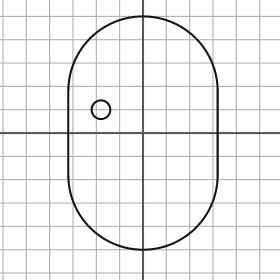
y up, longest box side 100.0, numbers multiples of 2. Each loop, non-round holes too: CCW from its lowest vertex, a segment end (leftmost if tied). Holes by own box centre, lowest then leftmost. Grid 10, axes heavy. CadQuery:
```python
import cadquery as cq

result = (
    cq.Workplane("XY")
    .moveTo(-32.0, -18.0)
    .threePointArc((0.0, -50.0), (32.0, -18.0))
    .lineTo(32.0, 18.0)
    .threePointArc((0.0, 50.0), (-32.0, 18.0))
    .close()
    .moveTo(-18.0, 10.0)
    .circle(4.0)
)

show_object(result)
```